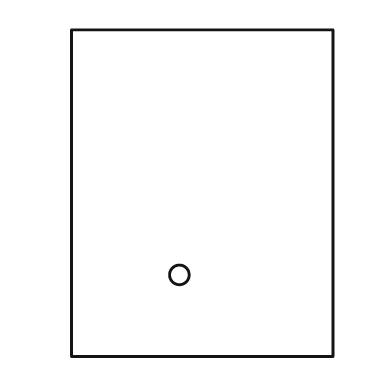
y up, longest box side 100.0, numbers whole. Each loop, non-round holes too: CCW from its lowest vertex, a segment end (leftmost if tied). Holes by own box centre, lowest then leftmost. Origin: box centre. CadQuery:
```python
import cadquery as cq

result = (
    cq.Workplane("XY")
    .moveTo(-40.0, -50.0)
    .lineTo(40.0, -50.0)
    .lineTo(40.0, 50.0)
    .lineTo(-40.0, 50.0)
    .close()
    .moveTo(-7.0, -25.0)
    .circle(3.0)
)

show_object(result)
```